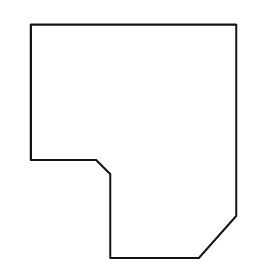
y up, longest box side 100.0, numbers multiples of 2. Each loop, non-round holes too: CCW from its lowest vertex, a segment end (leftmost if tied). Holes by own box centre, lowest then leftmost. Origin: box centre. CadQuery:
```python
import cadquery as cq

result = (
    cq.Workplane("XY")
    .moveTo(-10.0, -50.0)
    .lineTo(28.0, -50.0)
    .lineTo(44.0, -32.0)
    .lineTo(44.0, 50.0)
    .lineTo(-44.0, 50.0)
    .lineTo(-44.0, -8.0)
    .lineTo(-16.0, -8.0)
    .lineTo(-10.0, -14.0)
    .close()
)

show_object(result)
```